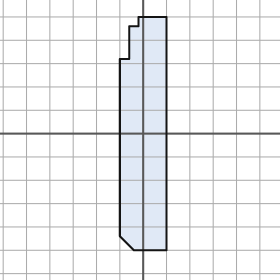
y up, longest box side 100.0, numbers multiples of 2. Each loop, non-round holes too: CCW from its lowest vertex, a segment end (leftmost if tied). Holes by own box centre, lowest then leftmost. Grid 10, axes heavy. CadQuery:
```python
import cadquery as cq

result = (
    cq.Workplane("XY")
    .moveTo(-4.0, -50.0)
    .lineTo(10.0, -50.0)
    .lineTo(10.0, 50.0)
    .lineTo(-2.0, 50.0)
    .lineTo(-2.0, 46.0)
    .lineTo(-6.0, 46.0)
    .lineTo(-6.0, 32.0)
    .lineTo(-10.0, 32.0)
    .lineTo(-10.0, -44.0)
    .close()
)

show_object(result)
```